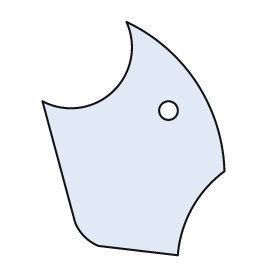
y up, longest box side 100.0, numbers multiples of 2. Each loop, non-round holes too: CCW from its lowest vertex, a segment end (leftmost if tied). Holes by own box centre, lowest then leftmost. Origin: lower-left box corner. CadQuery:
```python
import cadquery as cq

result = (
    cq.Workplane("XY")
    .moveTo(58.0, 0.0)
    .threePointArc((64.0, 20.0), (78.0, 36.0))
    .threePointArc((66.0, 74.0), (36.0, 100.0))
    .threePointArc((30.0, 70.0), (0.0, 66.0))
    .lineTo(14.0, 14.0)
    .threePointArc((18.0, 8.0), (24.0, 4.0))
    .close()
    .moveTo(54.0, 62.0)
    .circle(4.0)
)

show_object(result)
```